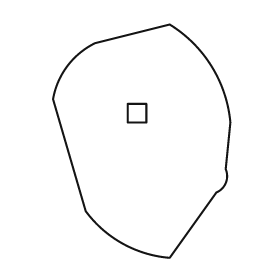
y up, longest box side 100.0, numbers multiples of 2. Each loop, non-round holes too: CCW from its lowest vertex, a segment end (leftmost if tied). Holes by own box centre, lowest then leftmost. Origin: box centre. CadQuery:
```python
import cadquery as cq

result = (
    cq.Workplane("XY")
    .moveTo(12.0, -50.0)
    .lineTo(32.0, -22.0)
    .threePointArc((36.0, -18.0), (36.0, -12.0))
    .lineTo(38.0, 8.0)
    .threePointArc((30.0, 32.0), (12.0, 50.0))
    .lineTo(-20.0, 42.0)
    .threePointArc((-32.0, 32.0), (-38.0, 18.0))
    .lineTo(-24.0, -30.0)
    .threePointArc((-8.0, -44.0), (12.0, -50.0))
    .close()
    .moveTo(-6.0, 8.0)
    .lineTo(2.0, 8.0)
    .lineTo(2.0, 16.0)
    .lineTo(-6.0, 16.0)
    .close()
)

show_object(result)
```